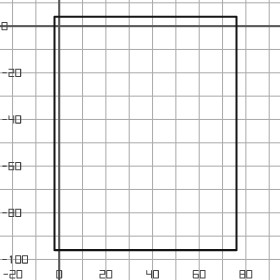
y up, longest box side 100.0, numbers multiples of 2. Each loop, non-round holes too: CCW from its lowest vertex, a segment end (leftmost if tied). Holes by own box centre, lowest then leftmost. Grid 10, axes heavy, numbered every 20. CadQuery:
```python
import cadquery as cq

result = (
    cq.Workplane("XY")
    .moveTo(-2.0, -96.0)
    .lineTo(76.0, -96.0)
    .lineTo(76.0, 4.0)
    .lineTo(-2.0, 4.0)
    .close()
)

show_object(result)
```